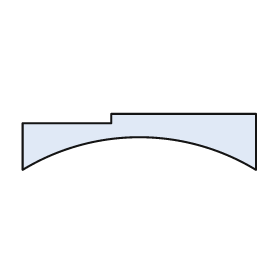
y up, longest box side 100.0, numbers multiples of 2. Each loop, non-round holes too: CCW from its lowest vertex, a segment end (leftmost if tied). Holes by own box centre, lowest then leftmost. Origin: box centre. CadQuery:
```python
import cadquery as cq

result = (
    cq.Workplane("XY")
    .moveTo(-50.0, -12.0)
    .threePointArc((0.0, 2.0), (50.0, -12.0))
    .lineTo(50.0, 12.0)
    .lineTo(-12.0, 12.0)
    .lineTo(-12.0, 8.0)
    .lineTo(-50.0, 8.0)
    .close()
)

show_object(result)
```